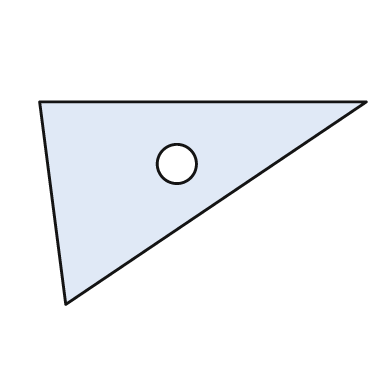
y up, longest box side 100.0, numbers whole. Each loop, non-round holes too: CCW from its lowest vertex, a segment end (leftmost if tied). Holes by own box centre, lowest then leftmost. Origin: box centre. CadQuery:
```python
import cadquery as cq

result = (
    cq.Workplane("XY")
    .moveTo(-42.0, -31.0)
    .lineTo(50.0, 31.0)
    .lineTo(-50.0, 31.0)
    .close()
    .moveTo(-8.0, 12.0)
    .circle(6.0)
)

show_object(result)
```